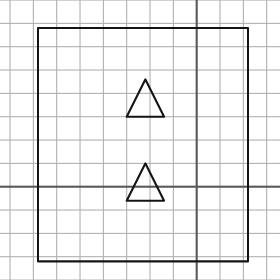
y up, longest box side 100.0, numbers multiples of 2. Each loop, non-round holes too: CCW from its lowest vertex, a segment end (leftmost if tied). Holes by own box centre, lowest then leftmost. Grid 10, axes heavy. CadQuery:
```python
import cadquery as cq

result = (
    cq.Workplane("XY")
    .moveTo(-68.0, -32.0)
    .lineTo(22.0, -32.0)
    .lineTo(22.0, 68.0)
    .lineTo(-68.0, 68.0)
    .close()
    .moveTo(-30.0, -6.0)
    .lineTo(-14.0, -6.0)
    .lineTo(-22.0, 10.0)
    .close()
    .moveTo(-30.0, 30.0)
    .lineTo(-14.0, 30.0)
    .lineTo(-22.0, 46.0)
    .close()
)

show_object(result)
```